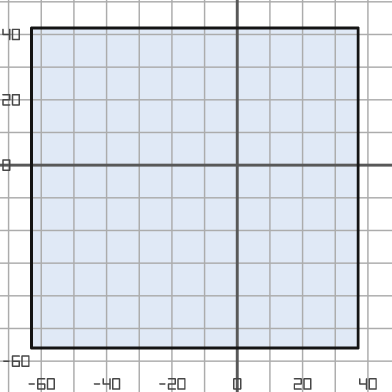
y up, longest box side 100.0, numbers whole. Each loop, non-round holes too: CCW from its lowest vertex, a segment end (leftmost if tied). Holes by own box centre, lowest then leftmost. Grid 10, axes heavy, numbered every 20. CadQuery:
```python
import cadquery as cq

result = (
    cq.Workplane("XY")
    .moveTo(-63.0, -56.0)
    .lineTo(37.0, -56.0)
    .lineTo(37.0, 42.0)
    .lineTo(-63.0, 42.0)
    .close()
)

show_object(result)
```